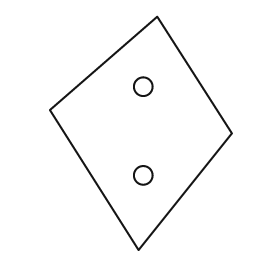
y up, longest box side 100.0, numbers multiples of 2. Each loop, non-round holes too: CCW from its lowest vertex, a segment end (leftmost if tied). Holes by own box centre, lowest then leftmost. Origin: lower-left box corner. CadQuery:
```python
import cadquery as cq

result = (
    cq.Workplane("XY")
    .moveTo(38.0, 0.0)
    .lineTo(78.0, 50.0)
    .lineTo(46.0, 100.0)
    .lineTo(0.0, 60.0)
    .close()
    .moveTo(40.0, 32.0)
    .circle(4.0)
    .moveTo(40.0, 70.0)
    .circle(4.0)
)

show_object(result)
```